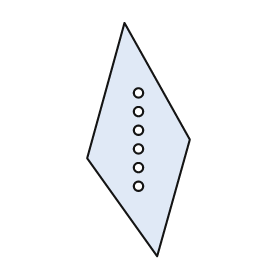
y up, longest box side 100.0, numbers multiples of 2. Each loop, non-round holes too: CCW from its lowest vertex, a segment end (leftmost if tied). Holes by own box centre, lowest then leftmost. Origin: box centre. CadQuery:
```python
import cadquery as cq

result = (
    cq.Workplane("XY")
    .moveTo(8.0, -50.0)
    .lineTo(22.0, 0.0)
    .lineTo(-6.0, 50.0)
    .lineTo(-22.0, -8.0)
    .close()
    .moveTo(0.0, -20.0)
    .circle(2.0)
    .moveTo(0.0, -12.0)
    .circle(2.0)
    .moveTo(0.0, -4.0)
    .circle(2.0)
    .moveTo(0.0, 4.0)
    .circle(2.0)
    .moveTo(0.0, 12.0)
    .circle(2.0)
    .moveTo(0.0, 20.0)
    .circle(2.0)
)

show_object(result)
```